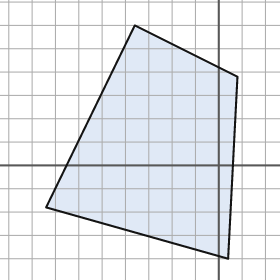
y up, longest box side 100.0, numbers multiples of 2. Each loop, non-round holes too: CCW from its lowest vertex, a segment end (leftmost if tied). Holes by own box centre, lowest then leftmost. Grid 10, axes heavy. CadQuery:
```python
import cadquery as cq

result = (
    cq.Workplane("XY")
    .moveTo(4.0, -40.0)
    .lineTo(8.0, 38.0)
    .lineTo(-36.0, 60.0)
    .lineTo(-74.0, -18.0)
    .close()
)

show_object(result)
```